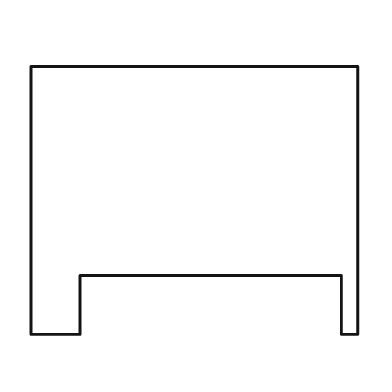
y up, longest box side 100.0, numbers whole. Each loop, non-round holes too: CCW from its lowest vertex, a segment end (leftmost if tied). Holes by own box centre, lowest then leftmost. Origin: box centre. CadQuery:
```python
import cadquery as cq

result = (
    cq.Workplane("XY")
    .moveTo(-50.0, -41.0)
    .lineTo(-35.0, -41.0)
    .lineTo(-35.0, -23.0)
    .lineTo(45.0, -23.0)
    .lineTo(45.0, -41.0)
    .lineTo(50.0, -41.0)
    .lineTo(50.0, 41.0)
    .lineTo(-50.0, 41.0)
    .close()
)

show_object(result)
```